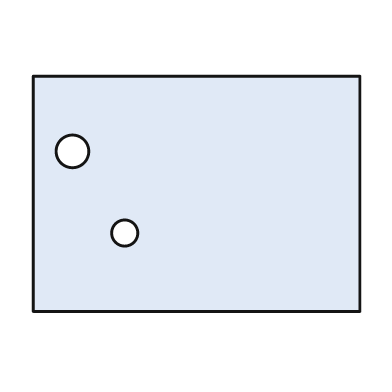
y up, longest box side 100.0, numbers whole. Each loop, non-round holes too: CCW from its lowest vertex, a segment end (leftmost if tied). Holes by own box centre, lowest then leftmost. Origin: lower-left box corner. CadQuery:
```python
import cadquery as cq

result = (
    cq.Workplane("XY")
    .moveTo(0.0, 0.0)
    .lineTo(100.0, 0.0)
    .lineTo(100.0, 72.0)
    .lineTo(0.0, 72.0)
    .close()
    .moveTo(28.0, 24.0)
    .circle(4.0)
    .moveTo(12.0, 49.0)
    .circle(5.0)
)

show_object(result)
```